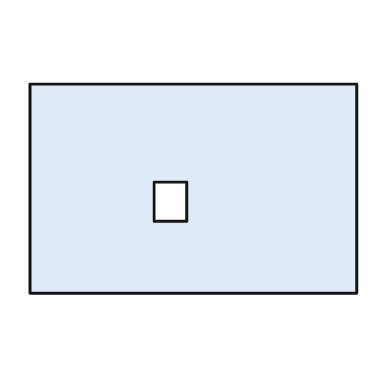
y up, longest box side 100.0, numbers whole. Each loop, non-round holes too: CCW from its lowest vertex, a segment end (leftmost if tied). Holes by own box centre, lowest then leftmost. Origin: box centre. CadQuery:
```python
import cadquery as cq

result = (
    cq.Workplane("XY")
    .moveTo(-50.0, -32.0)
    .lineTo(50.0, -32.0)
    .lineTo(50.0, 32.0)
    .lineTo(-50.0, 32.0)
    .close()
    .moveTo(-12.0, -10.0)
    .lineTo(-2.0, -10.0)
    .lineTo(-2.0, 2.0)
    .lineTo(-12.0, 2.0)
    .close()
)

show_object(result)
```